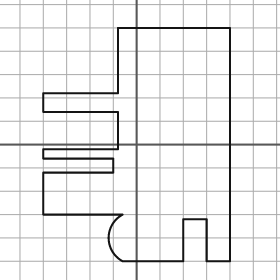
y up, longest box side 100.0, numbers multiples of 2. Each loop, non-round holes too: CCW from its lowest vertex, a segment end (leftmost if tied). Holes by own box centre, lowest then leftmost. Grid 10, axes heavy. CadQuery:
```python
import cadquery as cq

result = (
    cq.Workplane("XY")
    .moveTo(-6.0, -50.0)
    .lineTo(20.0, -50.0)
    .lineTo(20.0, -32.0)
    .lineTo(30.0, -32.0)
    .lineTo(30.0, -50.0)
    .lineTo(40.0, -50.0)
    .lineTo(40.0, 50.0)
    .lineTo(-8.0, 50.0)
    .lineTo(-8.0, 22.0)
    .lineTo(-40.0, 22.0)
    .lineTo(-40.0, 14.0)
    .lineTo(-8.0, 14.0)
    .lineTo(-8.0, -2.0)
    .lineTo(-40.0, -2.0)
    .lineTo(-40.0, -6.0)
    .lineTo(-10.0, -6.0)
    .lineTo(-10.0, -12.0)
    .lineTo(-40.0, -12.0)
    .lineTo(-40.0, -30.0)
    .lineTo(-6.0, -30.0)
    .threePointArc((-12.0, -40.0), (-6.0, -50.0))
    .close()
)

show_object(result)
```